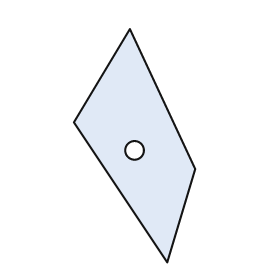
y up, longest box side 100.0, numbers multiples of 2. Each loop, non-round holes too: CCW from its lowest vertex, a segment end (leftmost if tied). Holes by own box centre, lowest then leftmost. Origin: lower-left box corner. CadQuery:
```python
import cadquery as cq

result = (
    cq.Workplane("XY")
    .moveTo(40.0, 0.0)
    .lineTo(52.0, 40.0)
    .lineTo(24.0, 100.0)
    .lineTo(0.0, 60.0)
    .close()
    .moveTo(26.0, 48.0)
    .circle(4.0)
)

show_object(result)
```